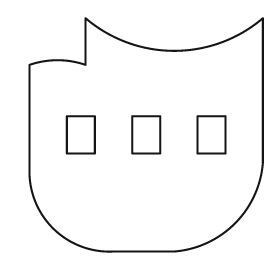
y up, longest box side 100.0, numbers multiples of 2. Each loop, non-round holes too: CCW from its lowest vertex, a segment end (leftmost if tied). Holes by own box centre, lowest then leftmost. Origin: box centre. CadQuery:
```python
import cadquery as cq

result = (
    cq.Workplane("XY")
    .moveTo(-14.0, -50.0)
    .lineTo(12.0, -50.0)
    .threePointArc((38.0, -38.0), (50.0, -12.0))
    .lineTo(50.0, 50.0)
    .threePointArc((12.0, 36.0), (-26.0, 50.0))
    .lineTo(-26.0, 30.0)
    .threePointArc((-38.0, 32.0), (-50.0, 30.0))
    .lineTo(-50.0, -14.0)
    .threePointArc((-40.0, -40.0), (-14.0, -50.0))
    .close()
    .moveTo(-34.0, -8.0)
    .lineTo(-22.0, -8.0)
    .lineTo(-22.0, 8.0)
    .lineTo(-34.0, 8.0)
    .close()
    .moveTo(-6.0, -8.0)
    .lineTo(6.0, -8.0)
    .lineTo(6.0, 8.0)
    .lineTo(-6.0, 8.0)
    .close()
    .moveTo(22.0, -8.0)
    .lineTo(34.0, -8.0)
    .lineTo(34.0, 8.0)
    .lineTo(22.0, 8.0)
    .close()
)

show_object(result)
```